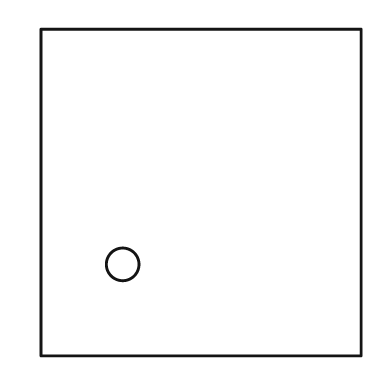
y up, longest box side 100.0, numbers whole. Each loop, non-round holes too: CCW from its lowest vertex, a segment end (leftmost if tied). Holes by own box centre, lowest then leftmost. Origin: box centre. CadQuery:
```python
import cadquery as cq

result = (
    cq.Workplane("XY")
    .moveTo(-49.0, -50.0)
    .lineTo(49.0, -50.0)
    .lineTo(49.0, 50.0)
    .lineTo(-49.0, 50.0)
    .close()
    .moveTo(-24.0, -22.0)
    .circle(5.0)
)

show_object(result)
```